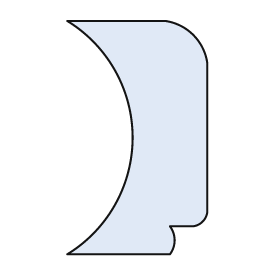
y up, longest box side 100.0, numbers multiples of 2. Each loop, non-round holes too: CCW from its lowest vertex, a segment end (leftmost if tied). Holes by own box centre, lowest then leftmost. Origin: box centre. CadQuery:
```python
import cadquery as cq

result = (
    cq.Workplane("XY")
    .moveTo(-30.0, -50.0)
    .lineTo(14.0, -50.0)
    .threePointArc((16.0, -44.0), (14.0, -38.0))
    .lineTo(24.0, -38.0)
    .threePointArc((28.0, -36.0), (30.0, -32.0))
    .lineTo(30.0, 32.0)
    .threePointArc((24.0, 44.0), (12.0, 50.0))
    .lineTo(-30.0, 50.0)
    .threePointArc((-2.0, 0.0), (-30.0, -50.0))
    .close()
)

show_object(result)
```